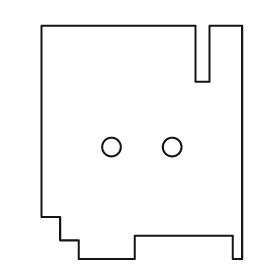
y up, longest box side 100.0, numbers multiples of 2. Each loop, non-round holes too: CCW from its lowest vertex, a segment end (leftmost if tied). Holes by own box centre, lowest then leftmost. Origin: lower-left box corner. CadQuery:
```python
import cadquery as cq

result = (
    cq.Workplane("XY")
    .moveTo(16.0, 0.0)
    .lineTo(40.0, 0.0)
    .lineTo(40.0, 10.0)
    .lineTo(82.0, 10.0)
    .lineTo(82.0, 0.0)
    .lineTo(86.0, 0.0)
    .lineTo(86.0, 100.0)
    .lineTo(72.0, 100.0)
    .lineTo(72.0, 76.0)
    .lineTo(66.0, 76.0)
    .lineTo(66.0, 100.0)
    .lineTo(0.0, 100.0)
    .lineTo(0.0, 18.0)
    .lineTo(8.0, 18.0)
    .lineTo(8.0, 8.0)
    .lineTo(16.0, 8.0)
    .close()
    .moveTo(30.0, 48.0)
    .circle(4.0)
    .moveTo(56.0, 48.0)
    .circle(4.0)
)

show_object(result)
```